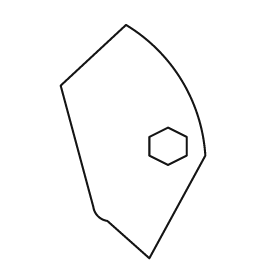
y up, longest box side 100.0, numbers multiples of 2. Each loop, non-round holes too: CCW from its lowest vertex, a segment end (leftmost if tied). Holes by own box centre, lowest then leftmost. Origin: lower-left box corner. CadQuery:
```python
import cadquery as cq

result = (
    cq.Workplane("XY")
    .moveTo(38.0, 0.0)
    .lineTo(62.0, 44.0)
    .threePointArc((52.0, 76.0), (28.0, 100.0))
    .lineTo(0.0, 74.0)
    .lineTo(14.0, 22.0)
    .threePointArc((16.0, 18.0), (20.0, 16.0))
    .close()
    .moveTo(46.0, 40.0)
    .lineTo(54.0, 44.0)
    .lineTo(54.0, 52.0)
    .lineTo(46.0, 56.0)
    .lineTo(38.0, 52.0)
    .lineTo(38.0, 44.0)
    .close()
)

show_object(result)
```